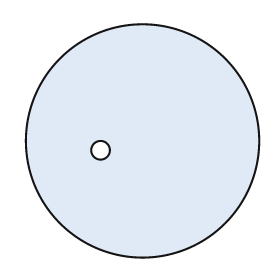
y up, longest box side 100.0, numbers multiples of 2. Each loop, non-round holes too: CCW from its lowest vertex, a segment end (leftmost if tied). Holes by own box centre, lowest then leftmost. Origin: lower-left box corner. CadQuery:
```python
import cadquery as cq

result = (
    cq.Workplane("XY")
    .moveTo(50.0, 50.0)
    .circle(50.0)
    .moveTo(32.0, 46.0)
    .circle(4.0)
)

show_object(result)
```